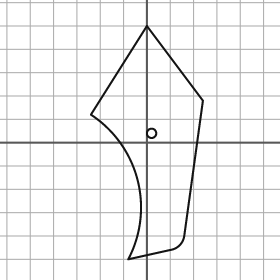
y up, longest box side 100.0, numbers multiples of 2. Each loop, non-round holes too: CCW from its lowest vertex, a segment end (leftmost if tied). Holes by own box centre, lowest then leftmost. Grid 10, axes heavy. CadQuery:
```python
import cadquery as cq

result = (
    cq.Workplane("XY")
    .moveTo(-8.0, -50.0)
    .lineTo(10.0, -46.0)
    .threePointArc((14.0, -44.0), (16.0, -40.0))
    .lineTo(24.0, 18.0)
    .lineTo(0.0, 50.0)
    .lineTo(-24.0, 12.0)
    .threePointArc((-4.0, -16.0), (-8.0, -50.0))
    .close()
    .moveTo(2.0, 4.0)
    .circle(2.0)
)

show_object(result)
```